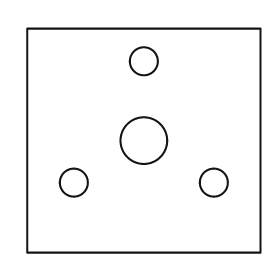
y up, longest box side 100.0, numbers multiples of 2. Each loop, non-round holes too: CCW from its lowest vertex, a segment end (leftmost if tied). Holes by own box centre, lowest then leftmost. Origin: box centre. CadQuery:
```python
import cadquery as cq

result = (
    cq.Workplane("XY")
    .moveTo(-50.0, -48.0)
    .lineTo(50.0, -48.0)
    .lineTo(50.0, 48.0)
    .lineTo(-50.0, 48.0)
    .close()
    .moveTo(-30.0, -18.0)
    .circle(6.0)
    .moveTo(30.0, -18.0)
    .circle(6.0)
    .moveTo(0.0, 0.0)
    .circle(10.0)
    .moveTo(0.0, 34.0)
    .circle(6.0)
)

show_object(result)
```